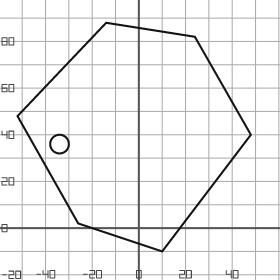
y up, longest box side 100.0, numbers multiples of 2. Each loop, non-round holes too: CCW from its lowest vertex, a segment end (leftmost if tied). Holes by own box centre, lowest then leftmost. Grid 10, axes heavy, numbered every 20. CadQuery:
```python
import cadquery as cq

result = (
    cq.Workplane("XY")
    .moveTo(10.0, -10.0)
    .lineTo(48.0, 40.0)
    .lineTo(24.0, 82.0)
    .lineTo(-14.0, 88.0)
    .lineTo(-52.0, 48.0)
    .lineTo(-26.0, 2.0)
    .close()
    .moveTo(-34.0, 36.0)
    .circle(4.0)
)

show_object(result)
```